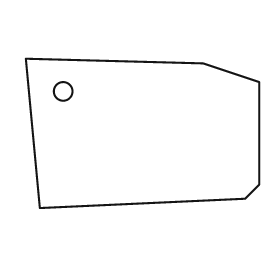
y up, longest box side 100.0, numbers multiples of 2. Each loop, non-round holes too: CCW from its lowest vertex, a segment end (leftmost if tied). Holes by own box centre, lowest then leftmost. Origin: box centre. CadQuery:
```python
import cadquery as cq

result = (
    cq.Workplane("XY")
    .moveTo(-44.0, -32.0)
    .lineTo(44.0, -28.0)
    .lineTo(50.0, -22.0)
    .lineTo(50.0, 22.0)
    .lineTo(26.0, 30.0)
    .lineTo(-50.0, 32.0)
    .close()
    .moveTo(-34.0, 18.0)
    .circle(4.0)
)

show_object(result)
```